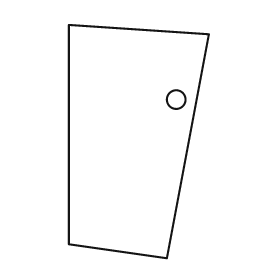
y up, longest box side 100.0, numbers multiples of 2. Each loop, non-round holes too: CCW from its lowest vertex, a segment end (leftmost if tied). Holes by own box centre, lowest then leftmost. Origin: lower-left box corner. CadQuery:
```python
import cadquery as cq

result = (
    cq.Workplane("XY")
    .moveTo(42.0, 0.0)
    .lineTo(60.0, 96.0)
    .lineTo(0.0, 100.0)
    .lineTo(0.0, 6.0)
    .close()
    .moveTo(46.0, 68.0)
    .circle(4.0)
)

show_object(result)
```